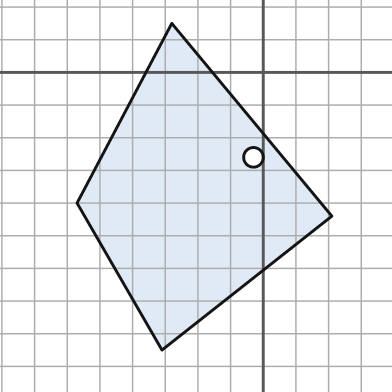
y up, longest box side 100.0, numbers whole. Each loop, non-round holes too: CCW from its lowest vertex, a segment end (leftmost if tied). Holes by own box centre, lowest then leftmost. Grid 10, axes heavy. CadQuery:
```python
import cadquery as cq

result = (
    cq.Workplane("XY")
    .moveTo(-31.0, -85.0)
    .lineTo(21.0, -44.0)
    .lineTo(-28.0, 15.0)
    .lineTo(-57.0, -40.0)
    .close()
    .moveTo(-3.0, -26.0)
    .circle(3.0)
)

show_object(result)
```